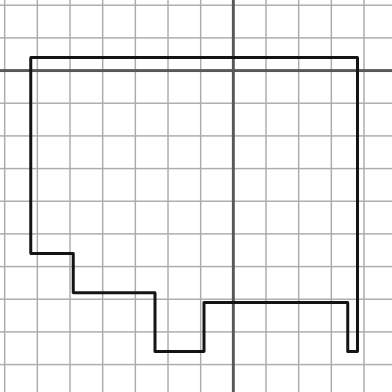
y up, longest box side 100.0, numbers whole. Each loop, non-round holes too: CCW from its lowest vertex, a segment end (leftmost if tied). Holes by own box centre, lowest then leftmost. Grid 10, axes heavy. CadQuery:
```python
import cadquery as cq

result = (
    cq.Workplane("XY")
    .moveTo(-24.0, -86.0)
    .lineTo(-9.0, -86.0)
    .lineTo(-9.0, -71.0)
    .lineTo(35.0, -71.0)
    .lineTo(35.0, -86.0)
    .lineTo(38.0, -86.0)
    .lineTo(38.0, 4.0)
    .lineTo(-62.0, 4.0)
    .lineTo(-62.0, -56.0)
    .lineTo(-49.0, -56.0)
    .lineTo(-49.0, -68.0)
    .lineTo(-24.0, -68.0)
    .close()
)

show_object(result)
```